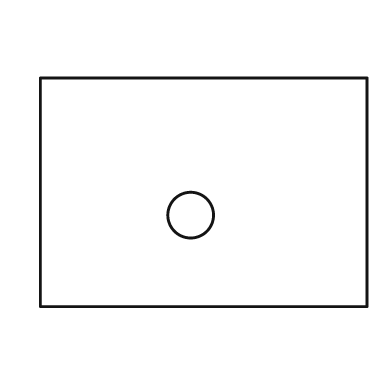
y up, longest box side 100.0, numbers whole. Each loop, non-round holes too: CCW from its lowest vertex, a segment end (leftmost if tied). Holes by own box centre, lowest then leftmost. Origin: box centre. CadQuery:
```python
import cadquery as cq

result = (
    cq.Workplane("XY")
    .moveTo(-50.0, -35.0)
    .lineTo(50.0, -35.0)
    .lineTo(50.0, 35.0)
    .lineTo(-50.0, 35.0)
    .close()
    .moveTo(-4.0, -7.0)
    .circle(7.0)
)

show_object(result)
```